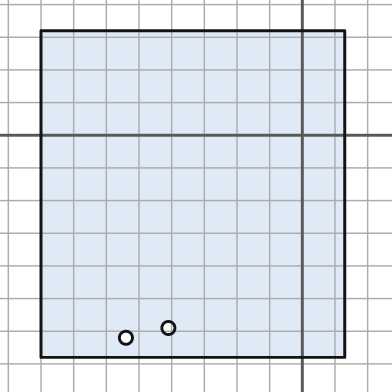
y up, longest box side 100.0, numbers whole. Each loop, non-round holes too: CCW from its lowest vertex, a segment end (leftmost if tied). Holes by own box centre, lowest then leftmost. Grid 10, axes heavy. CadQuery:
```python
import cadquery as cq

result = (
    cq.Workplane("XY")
    .moveTo(-80.0, -68.0)
    .lineTo(13.0, -68.0)
    .lineTo(13.0, 32.0)
    .lineTo(-80.0, 32.0)
    .close()
    .moveTo(-54.0, -62.0)
    .circle(2.0)
    .moveTo(-41.0, -59.0)
    .circle(2.0)
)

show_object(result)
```